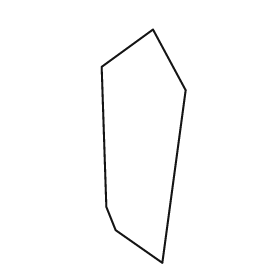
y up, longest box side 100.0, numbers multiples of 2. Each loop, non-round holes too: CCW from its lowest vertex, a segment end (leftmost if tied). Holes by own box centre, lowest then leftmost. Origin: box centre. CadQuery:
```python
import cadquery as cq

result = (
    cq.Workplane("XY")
    .moveTo(8.0, -50.0)
    .lineTo(18.0, 24.0)
    .lineTo(4.0, 50.0)
    .lineTo(-18.0, 34.0)
    .lineTo(-16.0, -26.0)
    .lineTo(-12.0, -36.0)
    .close()
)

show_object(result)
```